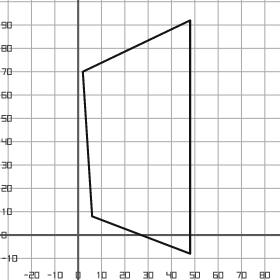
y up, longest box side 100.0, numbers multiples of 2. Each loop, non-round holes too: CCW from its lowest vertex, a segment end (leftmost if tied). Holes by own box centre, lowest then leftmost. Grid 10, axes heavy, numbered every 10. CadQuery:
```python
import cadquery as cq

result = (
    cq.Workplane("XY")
    .moveTo(48.0, -8.0)
    .lineTo(48.0, 92.0)
    .lineTo(2.0, 70.0)
    .lineTo(6.0, 8.0)
    .close()
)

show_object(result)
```